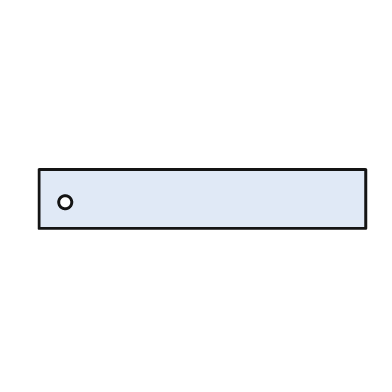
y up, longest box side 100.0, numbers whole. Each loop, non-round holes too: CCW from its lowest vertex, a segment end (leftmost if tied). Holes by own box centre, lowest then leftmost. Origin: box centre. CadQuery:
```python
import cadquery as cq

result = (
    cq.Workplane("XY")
    .moveTo(-50.0, -9.0)
    .lineTo(50.0, -9.0)
    .lineTo(50.0, 9.0)
    .lineTo(-50.0, 9.0)
    .close()
    .moveTo(-42.0, -1.0)
    .circle(2.0)
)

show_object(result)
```